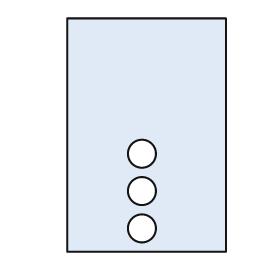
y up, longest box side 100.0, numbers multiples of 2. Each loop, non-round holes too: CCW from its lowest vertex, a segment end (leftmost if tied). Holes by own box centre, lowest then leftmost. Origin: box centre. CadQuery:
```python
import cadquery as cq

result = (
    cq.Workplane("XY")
    .moveTo(-34.0, -50.0)
    .lineTo(34.0, -50.0)
    .lineTo(34.0, 50.0)
    .lineTo(-34.0, 50.0)
    .close()
    .moveTo(-2.0, -40.0)
    .circle(6.0)
    .moveTo(-2.0, -24.0)
    .circle(6.0)
    .moveTo(-2.0, -8.0)
    .circle(6.0)
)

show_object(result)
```